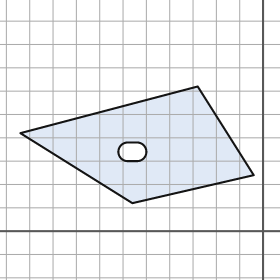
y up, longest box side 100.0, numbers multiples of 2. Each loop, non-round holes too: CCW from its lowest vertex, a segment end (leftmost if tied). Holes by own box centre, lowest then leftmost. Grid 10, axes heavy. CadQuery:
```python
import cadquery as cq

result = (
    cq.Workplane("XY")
    .moveTo(-56.0, 12.0)
    .lineTo(-4.0, 24.0)
    .lineTo(-28.0, 62.0)
    .lineTo(-104.0, 42.0)
    .close()
    .moveTo(-58.0, 30.0)
    .lineTo(-54.0, 30.0)
    .threePointArc((-50.0, 34.0), (-54.0, 38.0))
    .lineTo(-58.0, 38.0)
    .threePointArc((-62.0, 34.0), (-58.0, 30.0))
    .close()
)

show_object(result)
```